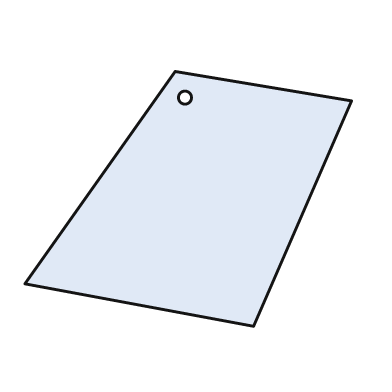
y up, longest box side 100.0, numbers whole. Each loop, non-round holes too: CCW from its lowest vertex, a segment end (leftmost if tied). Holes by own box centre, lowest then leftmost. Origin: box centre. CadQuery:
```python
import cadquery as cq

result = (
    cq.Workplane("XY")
    .moveTo(20.0, -39.0)
    .lineTo(50.0, 30.0)
    .lineTo(-4.0, 39.0)
    .lineTo(-50.0, -26.0)
    .close()
    .moveTo(-1.0, 31.0)
    .circle(2.0)
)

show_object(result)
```